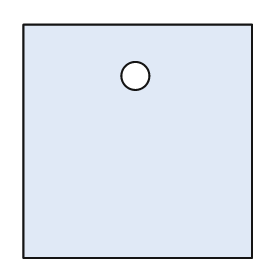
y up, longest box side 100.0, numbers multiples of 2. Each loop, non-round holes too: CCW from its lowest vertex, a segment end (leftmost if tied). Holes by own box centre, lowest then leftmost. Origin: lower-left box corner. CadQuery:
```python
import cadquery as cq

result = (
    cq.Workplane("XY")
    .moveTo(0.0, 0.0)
    .lineTo(98.0, 0.0)
    .lineTo(98.0, 100.0)
    .lineTo(0.0, 100.0)
    .close()
    .moveTo(48.0, 78.0)
    .circle(6.0)
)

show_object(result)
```